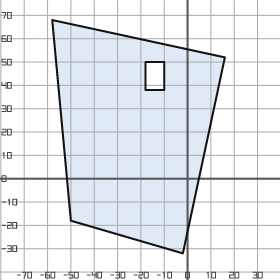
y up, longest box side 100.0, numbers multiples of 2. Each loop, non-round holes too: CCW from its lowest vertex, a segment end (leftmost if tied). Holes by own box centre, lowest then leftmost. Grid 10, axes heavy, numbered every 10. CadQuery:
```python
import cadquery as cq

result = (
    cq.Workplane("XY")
    .moveTo(-2.0, -32.0)
    .lineTo(16.0, 52.0)
    .lineTo(-58.0, 68.0)
    .lineTo(-50.0, -18.0)
    .close()
    .moveTo(-18.0, 38.0)
    .lineTo(-10.0, 38.0)
    .lineTo(-10.0, 50.0)
    .lineTo(-18.0, 50.0)
    .close()
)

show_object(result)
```